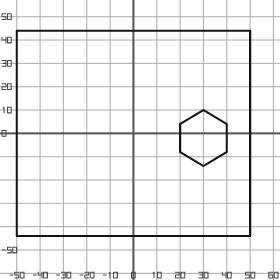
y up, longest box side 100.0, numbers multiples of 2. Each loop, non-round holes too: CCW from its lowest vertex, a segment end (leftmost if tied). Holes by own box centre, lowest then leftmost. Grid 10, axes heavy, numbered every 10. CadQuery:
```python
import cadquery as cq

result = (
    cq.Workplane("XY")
    .moveTo(-50.0, -44.0)
    .lineTo(50.0, -44.0)
    .lineTo(50.0, 44.0)
    .lineTo(-50.0, 44.0)
    .close()
    .moveTo(30.0, -14.0)
    .lineTo(40.0, -8.0)
    .lineTo(40.0, 4.0)
    .lineTo(30.0, 10.0)
    .lineTo(20.0, 4.0)
    .lineTo(20.0, -8.0)
    .close()
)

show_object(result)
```